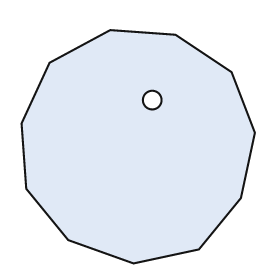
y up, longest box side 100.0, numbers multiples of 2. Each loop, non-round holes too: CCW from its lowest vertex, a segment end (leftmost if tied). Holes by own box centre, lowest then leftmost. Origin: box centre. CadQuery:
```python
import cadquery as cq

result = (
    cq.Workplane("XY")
    .moveTo(-2.0, -50.0)
    .lineTo(26.0, -44.0)
    .lineTo(44.0, -22.0)
    .lineTo(50.0, 6.0)
    .lineTo(40.0, 32.0)
    .lineTo(16.0, 48.0)
    .lineTo(-12.0, 50.0)
    .lineTo(-38.0, 36.0)
    .lineTo(-50.0, 10.0)
    .lineTo(-48.0, -18.0)
    .lineTo(-30.0, -40.0)
    .close()
    .moveTo(6.0, 20.0)
    .circle(4.0)
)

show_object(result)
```